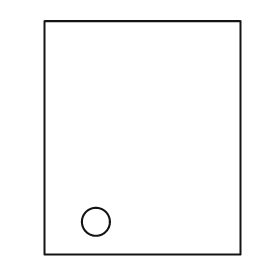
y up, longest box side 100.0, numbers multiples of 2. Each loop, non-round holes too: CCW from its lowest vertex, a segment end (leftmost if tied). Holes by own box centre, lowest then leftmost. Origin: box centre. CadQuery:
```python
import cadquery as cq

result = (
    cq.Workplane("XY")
    .moveTo(-42.0, -50.0)
    .lineTo(42.0, -50.0)
    .lineTo(42.0, 50.0)
    .lineTo(-42.0, 50.0)
    .close()
    .moveTo(-20.0, -36.0)
    .circle(6.0)
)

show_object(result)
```